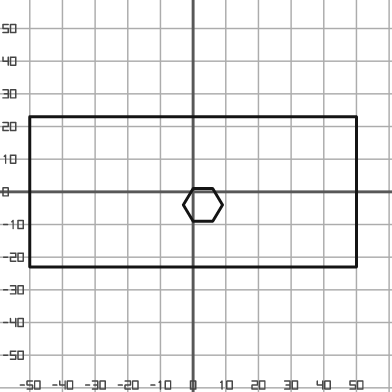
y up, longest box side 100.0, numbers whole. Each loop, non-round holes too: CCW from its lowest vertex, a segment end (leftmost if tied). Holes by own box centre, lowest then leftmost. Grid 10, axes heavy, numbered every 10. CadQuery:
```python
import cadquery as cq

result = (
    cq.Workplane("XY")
    .moveTo(-50.0, -23.0)
    .lineTo(50.0, -23.0)
    .lineTo(50.0, 23.0)
    .lineTo(-50.0, 23.0)
    .close()
    .moveTo(0.0, -9.0)
    .lineTo(6.0, -9.0)
    .lineTo(9.0, -4.0)
    .lineTo(6.0, 1.0)
    .lineTo(0.0, 1.0)
    .lineTo(-3.0, -4.0)
    .close()
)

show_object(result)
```